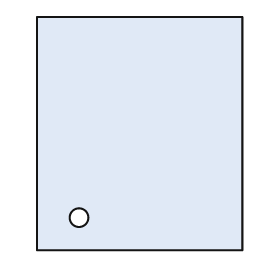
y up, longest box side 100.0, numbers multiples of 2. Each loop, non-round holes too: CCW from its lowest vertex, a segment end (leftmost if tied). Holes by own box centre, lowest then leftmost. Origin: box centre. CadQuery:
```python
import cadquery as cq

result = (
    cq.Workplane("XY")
    .moveTo(-44.0, -50.0)
    .lineTo(44.0, -50.0)
    .lineTo(44.0, 50.0)
    .lineTo(-44.0, 50.0)
    .close()
    .moveTo(-26.0, -36.0)
    .circle(4.0)
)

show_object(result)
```